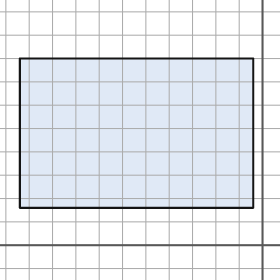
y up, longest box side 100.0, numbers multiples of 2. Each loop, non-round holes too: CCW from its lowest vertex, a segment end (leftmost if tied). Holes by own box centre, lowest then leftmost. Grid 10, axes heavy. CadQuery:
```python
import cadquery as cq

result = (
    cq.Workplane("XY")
    .moveTo(-104.0, 16.0)
    .lineTo(-4.0, 16.0)
    .lineTo(-4.0, 80.0)
    .lineTo(-104.0, 80.0)
    .close()
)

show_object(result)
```